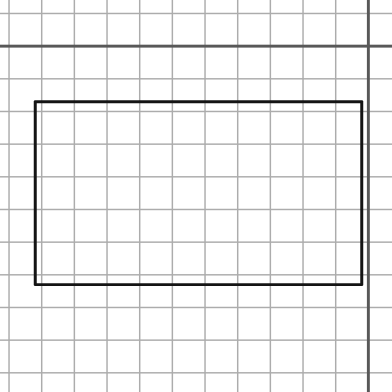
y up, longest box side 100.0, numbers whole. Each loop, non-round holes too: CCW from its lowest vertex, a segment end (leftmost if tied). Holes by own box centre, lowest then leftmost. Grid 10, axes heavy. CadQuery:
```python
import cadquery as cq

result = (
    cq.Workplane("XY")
    .moveTo(-102.0, -73.0)
    .lineTo(-2.0, -73.0)
    .lineTo(-2.0, -17.0)
    .lineTo(-102.0, -17.0)
    .close()
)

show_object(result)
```